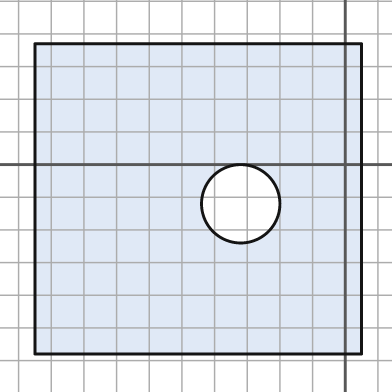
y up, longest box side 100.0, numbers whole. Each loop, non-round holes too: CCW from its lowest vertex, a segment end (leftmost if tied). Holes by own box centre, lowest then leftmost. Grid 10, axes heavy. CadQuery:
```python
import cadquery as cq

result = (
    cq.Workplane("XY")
    .moveTo(-95.0, -58.0)
    .lineTo(5.0, -58.0)
    .lineTo(5.0, 37.0)
    .lineTo(-95.0, 37.0)
    .close()
    .moveTo(-32.0, -12.0)
    .circle(12.0)
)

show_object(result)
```